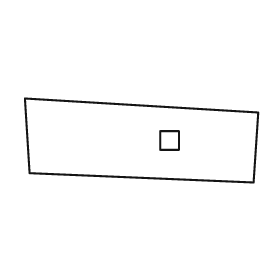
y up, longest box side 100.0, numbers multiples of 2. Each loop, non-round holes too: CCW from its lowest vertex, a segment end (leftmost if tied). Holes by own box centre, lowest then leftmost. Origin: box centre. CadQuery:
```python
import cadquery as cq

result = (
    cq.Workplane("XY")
    .moveTo(48.0, -18.0)
    .lineTo(50.0, 12.0)
    .lineTo(-50.0, 18.0)
    .lineTo(-48.0, -14.0)
    .close()
    .moveTo(8.0, -4.0)
    .lineTo(16.0, -4.0)
    .lineTo(16.0, 4.0)
    .lineTo(8.0, 4.0)
    .close()
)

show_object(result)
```